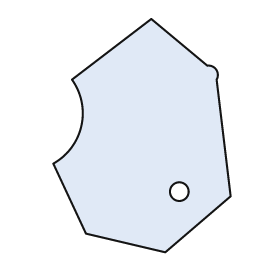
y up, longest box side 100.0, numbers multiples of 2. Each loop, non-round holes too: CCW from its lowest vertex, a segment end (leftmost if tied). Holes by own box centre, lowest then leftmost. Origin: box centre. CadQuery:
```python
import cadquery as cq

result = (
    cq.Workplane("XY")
    .moveTo(10.0, -50.0)
    .lineTo(38.0, -26.0)
    .lineTo(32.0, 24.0)
    .threePointArc((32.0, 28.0), (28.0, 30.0))
    .lineTo(4.0, 50.0)
    .lineTo(-30.0, 24.0)
    .threePointArc((-26.0, 4.0), (-38.0, -12.0))
    .lineTo(-24.0, -42.0)
    .close()
    .moveTo(16.0, -24.0)
    .circle(4.0)
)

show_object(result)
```